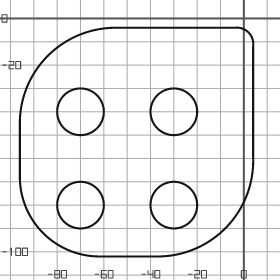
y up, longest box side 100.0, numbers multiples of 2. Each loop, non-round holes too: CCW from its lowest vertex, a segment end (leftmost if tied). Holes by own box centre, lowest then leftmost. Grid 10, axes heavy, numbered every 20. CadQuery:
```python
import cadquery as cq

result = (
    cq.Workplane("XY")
    .moveTo(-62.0, -102.0)
    .lineTo(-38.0, -102.0)
    .threePointArc((-8.0, -90.0), (4.0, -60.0))
    .lineTo(4.0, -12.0)
    .threePointArc((2.0, -6.0), (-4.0, -4.0))
    .lineTo(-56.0, -4.0)
    .threePointArc((-84.0, -16.0), (-96.0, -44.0))
    .lineTo(-96.0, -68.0)
    .threePointArc((-86.0, -92.0), (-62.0, -102.0))
    .close()
    .moveTo(-70.0, -80.0)
    .circle(10.0)
    .moveTo(-30.0, -80.0)
    .circle(10.0)
    .moveTo(-70.0, -40.0)
    .circle(10.0)
    .moveTo(-30.0, -40.0)
    .circle(10.0)
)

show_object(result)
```